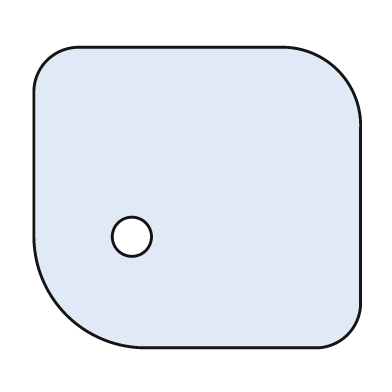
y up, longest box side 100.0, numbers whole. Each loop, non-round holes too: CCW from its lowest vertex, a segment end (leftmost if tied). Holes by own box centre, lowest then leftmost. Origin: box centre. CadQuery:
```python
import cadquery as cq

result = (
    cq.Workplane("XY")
    .moveTo(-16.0, -46.0)
    .lineTo(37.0, -46.0)
    .threePointArc((46.0, -42.0), (50.0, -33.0))
    .lineTo(50.0, 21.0)
    .threePointArc((43.0, 39.0), (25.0, 46.0))
    .lineTo(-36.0, 46.0)
    .threePointArc((-46.0, 42.0), (-50.0, 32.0))
    .lineTo(-50.0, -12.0)
    .threePointArc((-40.0, -36.0), (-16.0, -46.0))
    .close()
    .moveTo(-20.0, -12.0)
    .circle(6.0)
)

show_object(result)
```